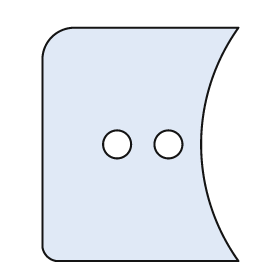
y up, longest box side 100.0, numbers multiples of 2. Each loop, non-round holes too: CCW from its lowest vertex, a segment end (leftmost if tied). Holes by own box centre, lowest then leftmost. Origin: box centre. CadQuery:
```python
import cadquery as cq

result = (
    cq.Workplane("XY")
    .moveTo(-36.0, -50.0)
    .lineTo(42.0, -50.0)
    .threePointArc((26.0, 0.0), (42.0, 50.0))
    .lineTo(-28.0, 50.0)
    .threePointArc((-38.0, 46.0), (-42.0, 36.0))
    .lineTo(-42.0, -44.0)
    .threePointArc((-40.0, -48.0), (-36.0, -50.0))
    .close()
    .moveTo(-10.0, 0.0)
    .circle(6.0)
    .moveTo(12.0, 0.0)
    .circle(6.0)
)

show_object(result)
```